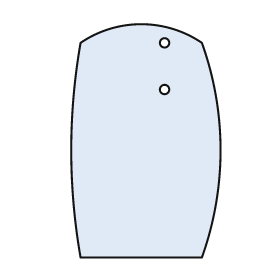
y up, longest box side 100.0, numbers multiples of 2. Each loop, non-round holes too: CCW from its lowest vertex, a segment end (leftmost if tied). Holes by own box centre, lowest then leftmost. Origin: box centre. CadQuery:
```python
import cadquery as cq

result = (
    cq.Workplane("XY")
    .moveTo(-28.0, -50.0)
    .lineTo(24.0, -50.0)
    .threePointArc((32.0, -4.0), (24.0, 42.0))
    .threePointArc((-2.0, 50.0), (-28.0, 42.0))
    .threePointArc((-32.0, -4.0), (-28.0, -50.0))
    .close()
    .moveTo(8.0, 22.0)
    .circle(2.0)
    .moveTo(8.0, 42.0)
    .circle(2.0)
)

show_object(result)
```